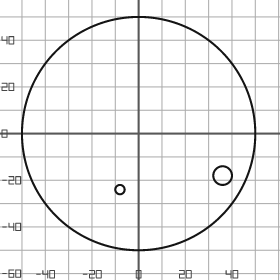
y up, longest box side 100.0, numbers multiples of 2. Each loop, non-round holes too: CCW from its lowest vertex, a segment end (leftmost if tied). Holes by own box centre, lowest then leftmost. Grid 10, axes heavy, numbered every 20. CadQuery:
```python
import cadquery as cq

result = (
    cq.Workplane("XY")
    .moveTo(0.0, 0.0)
    .circle(50.0)
    .moveTo(-8.0, -24.0)
    .circle(2.0)
    .moveTo(36.0, -18.0)
    .circle(4.0)
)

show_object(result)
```